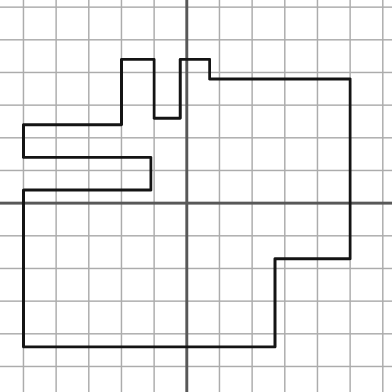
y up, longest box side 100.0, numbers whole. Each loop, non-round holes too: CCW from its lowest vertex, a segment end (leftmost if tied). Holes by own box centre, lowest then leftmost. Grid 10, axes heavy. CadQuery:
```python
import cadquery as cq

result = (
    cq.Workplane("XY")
    .moveTo(-50.0, -44.0)
    .lineTo(27.0, -44.0)
    .lineTo(27.0, -17.0)
    .lineTo(50.0, -17.0)
    .lineTo(50.0, 38.0)
    .lineTo(7.0, 38.0)
    .lineTo(7.0, 44.0)
    .lineTo(-2.0, 44.0)
    .lineTo(-2.0, 26.0)
    .lineTo(-10.0, 26.0)
    .lineTo(-10.0, 44.0)
    .lineTo(-20.0, 44.0)
    .lineTo(-20.0, 24.0)
    .lineTo(-50.0, 24.0)
    .lineTo(-50.0, 14.0)
    .lineTo(-11.0, 14.0)
    .lineTo(-11.0, 4.0)
    .lineTo(-50.0, 4.0)
    .close()
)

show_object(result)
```